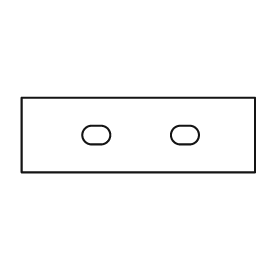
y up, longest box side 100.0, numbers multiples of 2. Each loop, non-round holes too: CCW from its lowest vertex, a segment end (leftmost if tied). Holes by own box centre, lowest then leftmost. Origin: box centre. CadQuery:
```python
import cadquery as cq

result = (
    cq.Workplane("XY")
    .moveTo(-50.0, -16.0)
    .lineTo(50.0, -16.0)
    .lineTo(50.0, 16.0)
    .lineTo(-50.0, 16.0)
    .close()
    .moveTo(-20.0, -4.0)
    .lineTo(-16.0, -4.0)
    .threePointArc((-12.0, 0.0), (-16.0, 4.0))
    .lineTo(-20.0, 4.0)
    .threePointArc((-24.0, 0.0), (-20.0, -4.0))
    .close()
    .moveTo(18.0, -4.0)
    .lineTo(22.0, -4.0)
    .threePointArc((26.0, 0.0), (22.0, 4.0))
    .lineTo(18.0, 4.0)
    .threePointArc((14.0, 0.0), (18.0, -4.0))
    .close()
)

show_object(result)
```